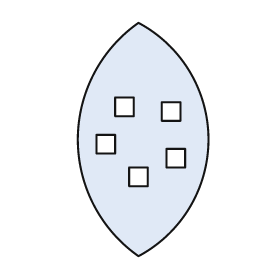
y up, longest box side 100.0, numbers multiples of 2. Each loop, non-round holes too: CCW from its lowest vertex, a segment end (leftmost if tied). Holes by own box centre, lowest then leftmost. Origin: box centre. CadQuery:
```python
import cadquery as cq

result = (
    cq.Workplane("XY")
    .moveTo(-2.0, -50.0)
    .threePointArc((28.0, 0.0), (-2.0, 50.0))
    .threePointArc((-28.0, 0.0), (-2.0, -50.0))
    .close()
    .moveTo(-6.0, -20.0)
    .lineTo(2.0, -20.0)
    .lineTo(2.0, -12.0)
    .lineTo(-6.0, -12.0)
    .close()
    .moveTo(10.0, -12.0)
    .lineTo(18.0, -12.0)
    .lineTo(18.0, -4.0)
    .lineTo(10.0, -4.0)
    .close()
    .moveTo(-20.0, -6.0)
    .lineTo(-12.0, -6.0)
    .lineTo(-12.0, 2.0)
    .lineTo(-20.0, 2.0)
    .close()
    .moveTo(8.0, 8.0)
    .lineTo(16.0, 8.0)
    .lineTo(16.0, 16.0)
    .lineTo(8.0, 16.0)
    .close()
    .moveTo(-12.0, 10.0)
    .lineTo(-4.0, 10.0)
    .lineTo(-4.0, 18.0)
    .lineTo(-12.0, 18.0)
    .close()
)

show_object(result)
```